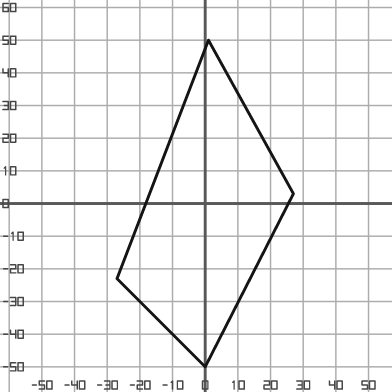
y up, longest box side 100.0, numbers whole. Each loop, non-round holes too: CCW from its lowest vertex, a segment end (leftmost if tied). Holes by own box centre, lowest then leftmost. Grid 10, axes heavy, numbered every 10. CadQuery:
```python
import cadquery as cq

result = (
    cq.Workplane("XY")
    .moveTo(0.0, -50.0)
    .lineTo(27.0, 3.0)
    .lineTo(1.0, 50.0)
    .lineTo(-27.0, -23.0)
    .close()
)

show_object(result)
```